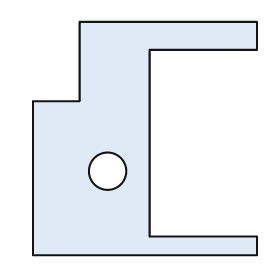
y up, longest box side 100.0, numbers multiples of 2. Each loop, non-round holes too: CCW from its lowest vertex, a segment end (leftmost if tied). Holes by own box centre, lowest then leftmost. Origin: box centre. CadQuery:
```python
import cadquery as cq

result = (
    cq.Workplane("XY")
    .moveTo(-48.0, -50.0)
    .lineTo(48.0, -50.0)
    .lineTo(48.0, -42.0)
    .lineTo(2.0, -42.0)
    .lineTo(2.0, 38.0)
    .lineTo(48.0, 38.0)
    .lineTo(48.0, 50.0)
    .lineTo(-28.0, 50.0)
    .lineTo(-28.0, 16.0)
    .lineTo(-48.0, 16.0)
    .close()
    .moveTo(-16.0, -14.0)
    .circle(8.0)
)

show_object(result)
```